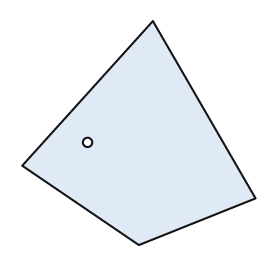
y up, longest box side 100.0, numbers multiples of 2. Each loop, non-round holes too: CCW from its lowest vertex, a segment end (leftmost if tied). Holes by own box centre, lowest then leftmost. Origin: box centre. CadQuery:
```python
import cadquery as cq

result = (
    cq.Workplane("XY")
    .moveTo(0.0, -48.0)
    .lineTo(50.0, -28.0)
    .lineTo(6.0, 48.0)
    .lineTo(-50.0, -14.0)
    .close()
    .moveTo(-22.0, -4.0)
    .circle(2.0)
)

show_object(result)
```